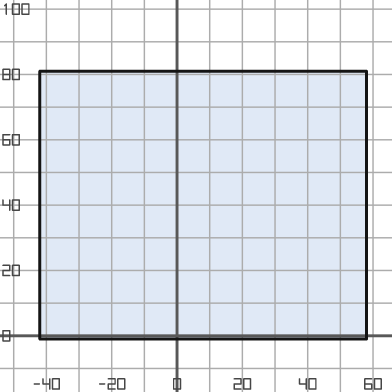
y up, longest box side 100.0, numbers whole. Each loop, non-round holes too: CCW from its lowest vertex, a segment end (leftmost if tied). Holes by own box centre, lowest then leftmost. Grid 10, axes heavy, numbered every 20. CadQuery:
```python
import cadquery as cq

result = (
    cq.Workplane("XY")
    .moveTo(-42.0, -1.0)
    .lineTo(58.0, -1.0)
    .lineTo(58.0, 81.0)
    .lineTo(-42.0, 81.0)
    .close()
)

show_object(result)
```